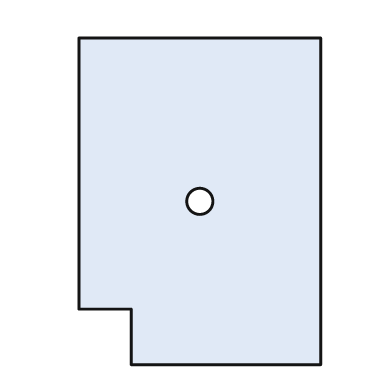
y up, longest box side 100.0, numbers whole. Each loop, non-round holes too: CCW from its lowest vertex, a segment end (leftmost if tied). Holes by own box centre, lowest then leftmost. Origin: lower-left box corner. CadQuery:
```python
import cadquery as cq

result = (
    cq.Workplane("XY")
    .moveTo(16.0, 0.0)
    .lineTo(74.0, 0.0)
    .lineTo(74.0, 100.0)
    .lineTo(0.0, 100.0)
    .lineTo(0.0, 17.0)
    .lineTo(16.0, 17.0)
    .close()
    .moveTo(37.0, 50.0)
    .circle(4.0)
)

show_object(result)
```